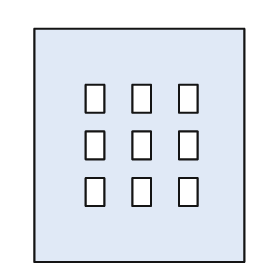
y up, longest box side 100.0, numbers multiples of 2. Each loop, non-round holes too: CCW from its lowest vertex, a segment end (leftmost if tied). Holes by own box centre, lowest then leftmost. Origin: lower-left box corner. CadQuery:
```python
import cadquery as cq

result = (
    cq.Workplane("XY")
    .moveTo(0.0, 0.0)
    .lineTo(90.0, 0.0)
    .lineTo(90.0, 100.0)
    .lineTo(0.0, 100.0)
    .close()
    .moveTo(22.0, 24.0)
    .lineTo(30.0, 24.0)
    .lineTo(30.0, 36.0)
    .lineTo(22.0, 36.0)
    .close()
    .moveTo(42.0, 24.0)
    .lineTo(50.0, 24.0)
    .lineTo(50.0, 36.0)
    .lineTo(42.0, 36.0)
    .close()
    .moveTo(62.0, 24.0)
    .lineTo(70.0, 24.0)
    .lineTo(70.0, 36.0)
    .lineTo(62.0, 36.0)
    .close()
    .moveTo(22.0, 44.0)
    .lineTo(30.0, 44.0)
    .lineTo(30.0, 56.0)
    .lineTo(22.0, 56.0)
    .close()
    .moveTo(42.0, 44.0)
    .lineTo(50.0, 44.0)
    .lineTo(50.0, 56.0)
    .lineTo(42.0, 56.0)
    .close()
    .moveTo(62.0, 44.0)
    .lineTo(70.0, 44.0)
    .lineTo(70.0, 56.0)
    .lineTo(62.0, 56.0)
    .close()
    .moveTo(22.0, 64.0)
    .lineTo(30.0, 64.0)
    .lineTo(30.0, 76.0)
    .lineTo(22.0, 76.0)
    .close()
    .moveTo(42.0, 64.0)
    .lineTo(50.0, 64.0)
    .lineTo(50.0, 76.0)
    .lineTo(42.0, 76.0)
    .close()
    .moveTo(62.0, 64.0)
    .lineTo(70.0, 64.0)
    .lineTo(70.0, 76.0)
    .lineTo(62.0, 76.0)
    .close()
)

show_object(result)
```